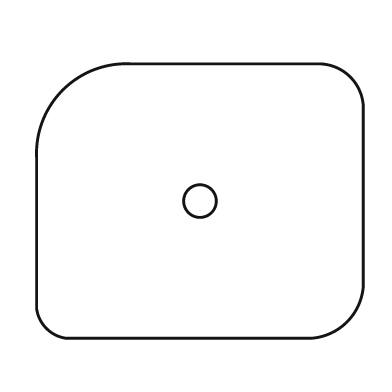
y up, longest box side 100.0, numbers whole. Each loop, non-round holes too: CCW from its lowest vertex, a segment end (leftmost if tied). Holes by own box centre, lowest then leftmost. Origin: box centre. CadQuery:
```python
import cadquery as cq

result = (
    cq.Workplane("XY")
    .moveTo(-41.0, -42.0)
    .lineTo(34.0, -42.0)
    .threePointArc((45.0, -37.0), (50.0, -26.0))
    .lineTo(50.0, 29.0)
    .threePointArc((46.0, 38.0), (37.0, 42.0))
    .lineTo(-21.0, 42.0)
    .threePointArc((-42.0, 34.0), (-50.0, 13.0))
    .lineTo(-50.0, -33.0)
    .threePointArc((-47.0, -39.0), (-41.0, -42.0))
    .close()
    .moveTo(0.0, 0.0)
    .circle(5.0)
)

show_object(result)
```